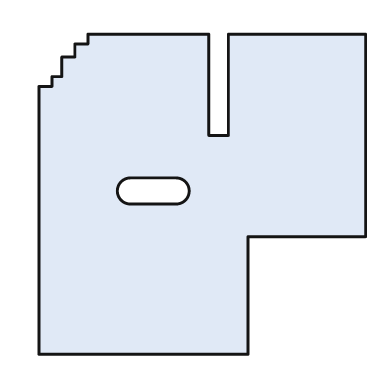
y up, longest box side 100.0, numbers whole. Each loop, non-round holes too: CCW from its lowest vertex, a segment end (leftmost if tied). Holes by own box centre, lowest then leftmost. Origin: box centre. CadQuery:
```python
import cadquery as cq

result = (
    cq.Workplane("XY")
    .moveTo(-50.0, -49.0)
    .lineTo(14.0, -49.0)
    .lineTo(14.0, -13.0)
    .lineTo(50.0, -13.0)
    .lineTo(50.0, 49.0)
    .lineTo(8.0, 49.0)
    .lineTo(8.0, 18.0)
    .lineTo(2.0, 18.0)
    .lineTo(2.0, 49.0)
    .lineTo(-35.0, 49.0)
    .lineTo(-35.0, 46.0)
    .lineTo(-39.0, 46.0)
    .lineTo(-39.0, 42.0)
    .lineTo(-43.0, 42.0)
    .lineTo(-43.0, 36.0)
    .lineTo(-46.0, 36.0)
    .lineTo(-46.0, 33.0)
    .lineTo(-50.0, 33.0)
    .close()
    .moveTo(-22.0, -3.0)
    .lineTo(-8.0, -3.0)
    .threePointArc((-4.0, 1.0), (-8.0, 5.0))
    .lineTo(-22.0, 5.0)
    .threePointArc((-26.0, 1.0), (-22.0, -3.0))
    .close()
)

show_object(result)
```